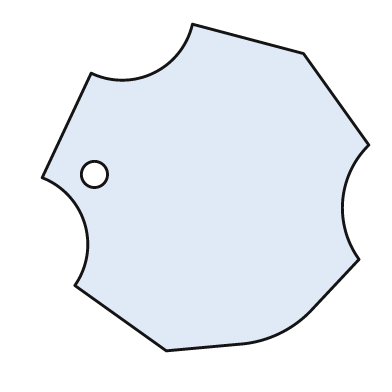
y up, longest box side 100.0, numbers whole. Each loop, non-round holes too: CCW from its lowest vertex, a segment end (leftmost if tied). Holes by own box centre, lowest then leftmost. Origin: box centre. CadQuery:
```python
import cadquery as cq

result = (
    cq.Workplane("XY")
    .moveTo(-12.0, -50.0)
    .lineTo(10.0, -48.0)
    .threePointArc((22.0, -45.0), (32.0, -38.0))
    .lineTo(47.0, -22.0)
    .threePointArc((42.0, -4.0), (50.0, 13.0))
    .lineTo(30.0, 41.0)
    .lineTo(-4.0, 50.0)
    .threePointArc((-16.0, 35.0), (-35.0, 35.0))
    .lineTo(-50.0, 3.0)
    .threePointArc((-37.0, -11.0), (-40.0, -30.0))
    .close()
    .moveTo(-34.0, 4.0)
    .circle(4.0)
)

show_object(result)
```